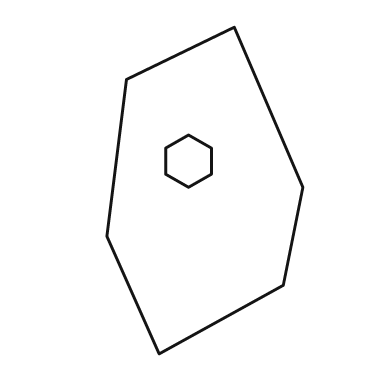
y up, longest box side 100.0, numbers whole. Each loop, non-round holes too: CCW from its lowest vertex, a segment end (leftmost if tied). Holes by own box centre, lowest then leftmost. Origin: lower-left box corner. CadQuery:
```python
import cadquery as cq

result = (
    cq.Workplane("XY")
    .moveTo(16.0, 0.0)
    .lineTo(54.0, 21.0)
    .lineTo(60.0, 51.0)
    .lineTo(39.0, 100.0)
    .lineTo(6.0, 84.0)
    .lineTo(0.0, 36.0)
    .close()
    .moveTo(25.0, 51.0)
    .lineTo(32.0, 55.0)
    .lineTo(32.0, 63.0)
    .lineTo(25.0, 67.0)
    .lineTo(18.0, 63.0)
    .lineTo(18.0, 55.0)
    .close()
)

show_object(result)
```